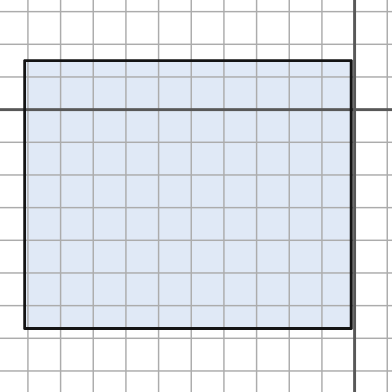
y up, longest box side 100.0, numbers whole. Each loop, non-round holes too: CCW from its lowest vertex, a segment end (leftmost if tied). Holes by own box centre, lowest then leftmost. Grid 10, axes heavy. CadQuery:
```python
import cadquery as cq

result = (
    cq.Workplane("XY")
    .moveTo(-101.0, -67.0)
    .lineTo(-1.0, -67.0)
    .lineTo(-1.0, 15.0)
    .lineTo(-101.0, 15.0)
    .close()
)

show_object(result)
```